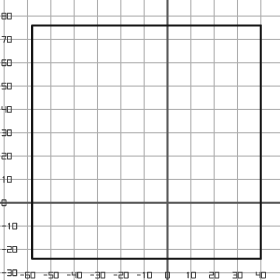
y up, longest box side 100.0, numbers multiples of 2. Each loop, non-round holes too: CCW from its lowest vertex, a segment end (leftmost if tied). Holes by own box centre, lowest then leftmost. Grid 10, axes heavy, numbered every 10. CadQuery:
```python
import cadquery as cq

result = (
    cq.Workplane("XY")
    .moveTo(-58.0, -24.0)
    .lineTo(40.0, -24.0)
    .lineTo(40.0, 76.0)
    .lineTo(-58.0, 76.0)
    .close()
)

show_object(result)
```